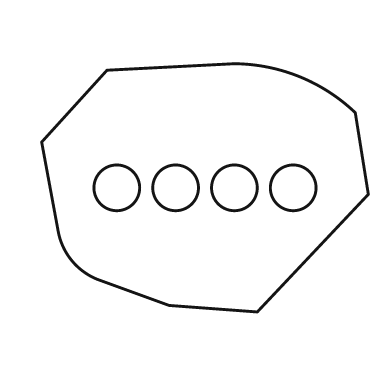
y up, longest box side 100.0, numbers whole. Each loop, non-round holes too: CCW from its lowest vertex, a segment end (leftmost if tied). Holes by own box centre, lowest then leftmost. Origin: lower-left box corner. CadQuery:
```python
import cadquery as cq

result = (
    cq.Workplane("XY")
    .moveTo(66.0, 0.0)
    .lineTo(100.0, 36.0)
    .lineTo(96.0, 61.0)
    .threePointArc((79.0, 72.0), (59.0, 76.0))
    .lineTo(20.0, 74.0)
    .lineTo(0.0, 52.0)
    .lineTo(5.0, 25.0)
    .threePointArc((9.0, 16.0), (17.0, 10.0))
    .lineTo(39.0, 2.0)
    .close()
    .moveTo(23.0, 38.0)
    .circle(7.0)
    .moveTo(41.0, 38.0)
    .circle(7.0)
    .moveTo(59.0, 38.0)
    .circle(7.0)
    .moveTo(77.0, 38.0)
    .circle(7.0)
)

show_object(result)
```